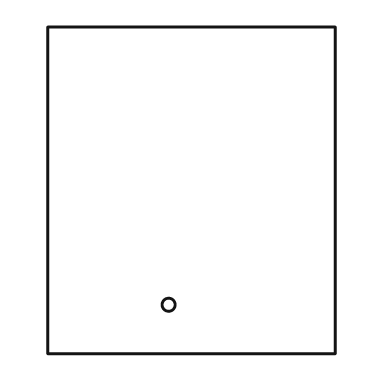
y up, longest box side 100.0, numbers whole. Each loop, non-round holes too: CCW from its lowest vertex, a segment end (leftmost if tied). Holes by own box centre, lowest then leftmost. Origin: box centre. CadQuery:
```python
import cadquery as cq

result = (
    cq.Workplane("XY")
    .moveTo(-44.0, -50.0)
    .lineTo(44.0, -50.0)
    .lineTo(44.0, 50.0)
    .lineTo(-44.0, 50.0)
    .close()
    .moveTo(-7.0, -35.0)
    .circle(2.0)
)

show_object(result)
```